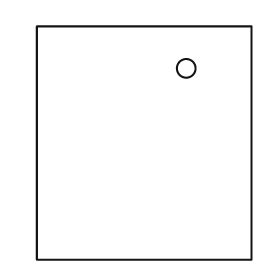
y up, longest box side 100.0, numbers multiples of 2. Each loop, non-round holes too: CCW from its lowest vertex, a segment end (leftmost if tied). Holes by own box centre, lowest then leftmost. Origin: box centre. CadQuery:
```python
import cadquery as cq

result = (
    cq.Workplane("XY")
    .moveTo(-46.0, -50.0)
    .lineTo(46.0, -50.0)
    .lineTo(46.0, 50.0)
    .lineTo(-46.0, 50.0)
    .close()
    .moveTo(18.0, 32.0)
    .circle(4.0)
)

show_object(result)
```